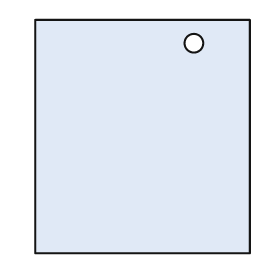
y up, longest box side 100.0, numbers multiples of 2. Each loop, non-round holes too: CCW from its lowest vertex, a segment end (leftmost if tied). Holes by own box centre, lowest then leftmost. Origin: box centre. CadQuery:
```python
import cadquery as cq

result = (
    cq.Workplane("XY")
    .moveTo(-46.0, -50.0)
    .lineTo(46.0, -50.0)
    .lineTo(46.0, 50.0)
    .lineTo(-46.0, 50.0)
    .close()
    .moveTo(22.0, 40.0)
    .circle(4.0)
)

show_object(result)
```